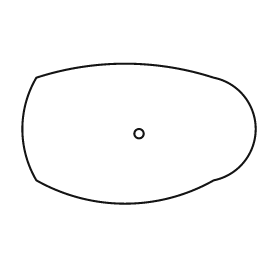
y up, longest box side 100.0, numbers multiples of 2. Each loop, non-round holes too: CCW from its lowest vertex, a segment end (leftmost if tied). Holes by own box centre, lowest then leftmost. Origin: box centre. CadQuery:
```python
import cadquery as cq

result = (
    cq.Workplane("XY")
    .moveTo(-44.0, -20.0)
    .threePointArc((-6.0, -30.0), (32.0, -20.0))
    .threePointArc((50.0, 2.0), (32.0, 24.0))
    .threePointArc((-6.0, 30.0), (-44.0, 24.0))
    .threePointArc((-50.0, 2.0), (-44.0, -20.0))
    .close()
    .moveTo(0.0, 0.0)
    .circle(2.0)
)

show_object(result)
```